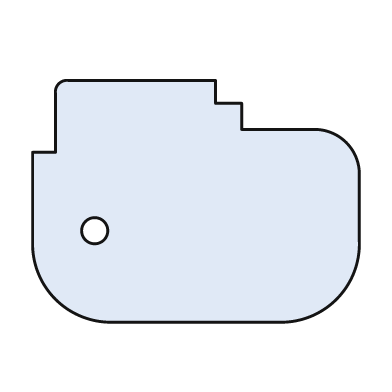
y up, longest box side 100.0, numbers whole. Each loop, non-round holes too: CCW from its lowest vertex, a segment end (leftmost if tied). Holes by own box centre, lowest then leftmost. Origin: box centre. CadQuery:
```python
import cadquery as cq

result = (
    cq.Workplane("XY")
    .moveTo(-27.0, -37.0)
    .lineTo(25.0, -37.0)
    .threePointArc((43.0, -30.0), (50.0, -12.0))
    .lineTo(50.0, 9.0)
    .threePointArc((46.0, 18.0), (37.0, 22.0))
    .lineTo(14.0, 22.0)
    .lineTo(14.0, 30.0)
    .lineTo(6.0, 30.0)
    .lineTo(6.0, 37.0)
    .lineTo(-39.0, 37.0)
    .threePointArc((-42.0, 36.0), (-43.0, 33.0))
    .lineTo(-43.0, 15.0)
    .lineTo(-50.0, 15.0)
    .lineTo(-50.0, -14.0)
    .threePointArc((-43.0, -30.0), (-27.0, -37.0))
    .close()
    .moveTo(-31.0, -9.0)
    .circle(4.0)
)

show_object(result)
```